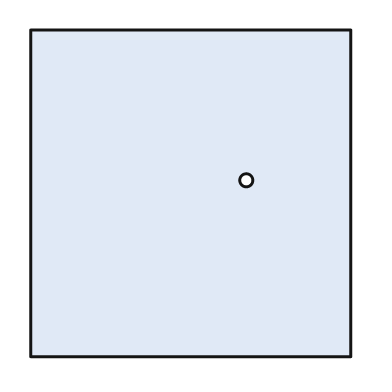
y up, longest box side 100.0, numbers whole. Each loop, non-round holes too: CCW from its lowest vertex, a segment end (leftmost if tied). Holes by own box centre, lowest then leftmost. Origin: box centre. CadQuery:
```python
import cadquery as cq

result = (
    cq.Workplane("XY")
    .moveTo(-49.0, -50.0)
    .lineTo(49.0, -50.0)
    .lineTo(49.0, 50.0)
    .lineTo(-49.0, 50.0)
    .close()
    .moveTo(17.0, 4.0)
    .circle(2.0)
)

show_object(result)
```